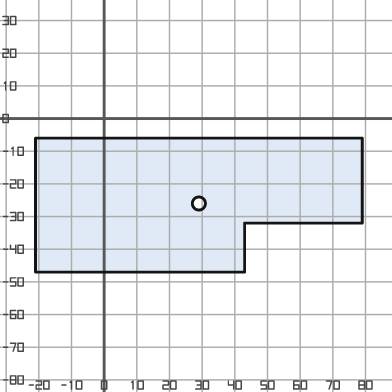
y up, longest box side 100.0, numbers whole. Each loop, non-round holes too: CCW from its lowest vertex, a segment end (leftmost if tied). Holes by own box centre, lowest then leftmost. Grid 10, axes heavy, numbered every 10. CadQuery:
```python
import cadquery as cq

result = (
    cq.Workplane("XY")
    .moveTo(-21.0, -47.0)
    .lineTo(43.0, -47.0)
    .lineTo(43.0, -32.0)
    .lineTo(79.0, -32.0)
    .lineTo(79.0, -6.0)
    .lineTo(-21.0, -6.0)
    .close()
    .moveTo(29.0, -26.0)
    .circle(2.0)
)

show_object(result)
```